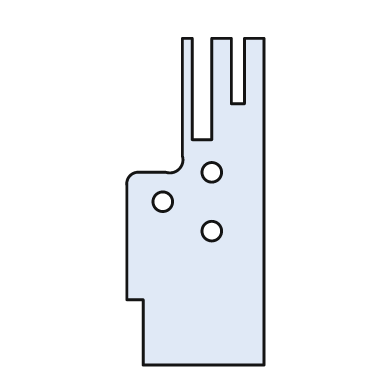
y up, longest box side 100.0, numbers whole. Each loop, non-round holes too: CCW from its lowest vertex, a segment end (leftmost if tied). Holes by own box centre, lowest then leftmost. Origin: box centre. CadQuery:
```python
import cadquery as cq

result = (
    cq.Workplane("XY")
    .moveTo(-16.0, -50.0)
    .lineTo(21.0, -50.0)
    .lineTo(21.0, 50.0)
    .lineTo(15.0, 50.0)
    .lineTo(15.0, 30.0)
    .lineTo(11.0, 30.0)
    .lineTo(11.0, 50.0)
    .lineTo(5.0, 50.0)
    .lineTo(5.0, 19.0)
    .lineTo(-1.0, 19.0)
    .lineTo(-1.0, 50.0)
    .lineTo(-4.0, 50.0)
    .lineTo(-4.0, 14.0)
    .threePointArc((-5.0, 10.0), (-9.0, 9.0))
    .lineTo(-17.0, 9.0)
    .threePointArc((-20.0, 8.0), (-21.0, 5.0))
    .lineTo(-21.0, -30.0)
    .lineTo(-16.0, -30.0)
    .close()
    .moveTo(5.0, -9.0)
    .circle(3.0)
    .moveTo(-10.0, 0.0)
    .circle(3.0)
    .moveTo(5.0, 9.0)
    .circle(3.0)
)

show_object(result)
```